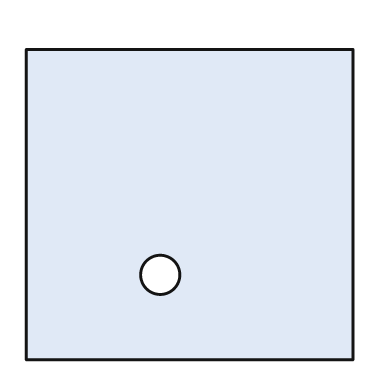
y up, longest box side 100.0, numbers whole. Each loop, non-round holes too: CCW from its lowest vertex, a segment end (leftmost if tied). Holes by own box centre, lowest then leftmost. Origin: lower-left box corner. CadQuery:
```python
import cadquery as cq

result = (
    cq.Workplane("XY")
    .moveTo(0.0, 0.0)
    .lineTo(100.0, 0.0)
    .lineTo(100.0, 95.0)
    .lineTo(0.0, 95.0)
    .close()
    .moveTo(41.0, 26.0)
    .circle(6.0)
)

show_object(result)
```